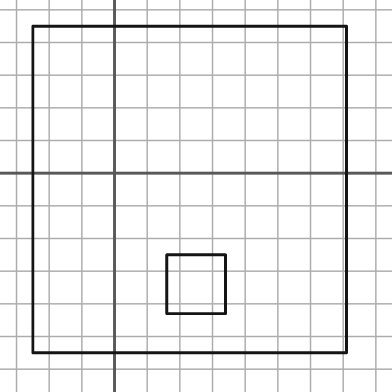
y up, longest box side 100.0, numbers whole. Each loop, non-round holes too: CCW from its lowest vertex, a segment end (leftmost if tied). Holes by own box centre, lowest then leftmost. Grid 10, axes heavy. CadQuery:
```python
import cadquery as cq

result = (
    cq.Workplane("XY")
    .moveTo(-25.0, -55.0)
    .lineTo(71.0, -55.0)
    .lineTo(71.0, 45.0)
    .lineTo(-25.0, 45.0)
    .close()
    .moveTo(16.0, -43.0)
    .lineTo(34.0, -43.0)
    .lineTo(34.0, -25.0)
    .lineTo(16.0, -25.0)
    .close()
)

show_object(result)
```